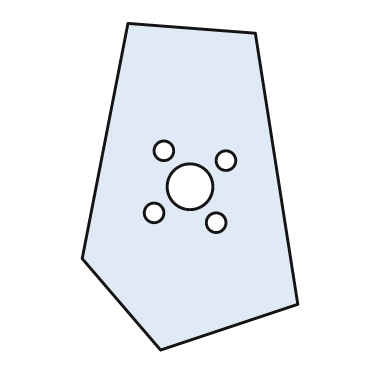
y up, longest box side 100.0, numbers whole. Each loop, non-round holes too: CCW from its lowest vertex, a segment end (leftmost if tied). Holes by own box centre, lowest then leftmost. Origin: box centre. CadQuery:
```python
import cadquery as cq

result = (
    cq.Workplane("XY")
    .moveTo(-9.0, -50.0)
    .lineTo(33.0, -36.0)
    .lineTo(20.0, 47.0)
    .lineTo(-19.0, 50.0)
    .lineTo(-33.0, -22.0)
    .close()
    .moveTo(8.0, -11.0)
    .circle(3.0)
    .moveTo(-11.0, -8.0)
    .circle(3.0)
    .moveTo(0.0, 0.0)
    .circle(7.0)
    .moveTo(11.0, 8.0)
    .circle(3.0)
    .moveTo(-8.0, 11.0)
    .circle(3.0)
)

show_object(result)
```